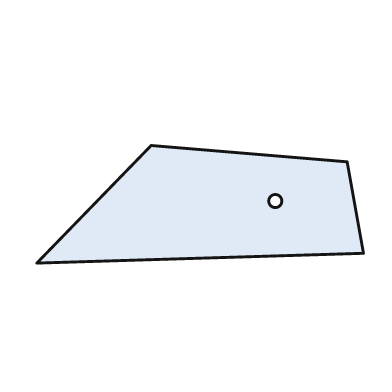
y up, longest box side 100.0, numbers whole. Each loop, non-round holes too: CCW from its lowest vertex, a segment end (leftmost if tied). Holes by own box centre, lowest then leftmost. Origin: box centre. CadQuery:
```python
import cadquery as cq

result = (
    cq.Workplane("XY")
    .moveTo(-50.0, -18.0)
    .lineTo(50.0, -15.0)
    .lineTo(45.0, 13.0)
    .lineTo(-15.0, 18.0)
    .close()
    .moveTo(23.0, 1.0)
    .circle(2.0)
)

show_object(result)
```